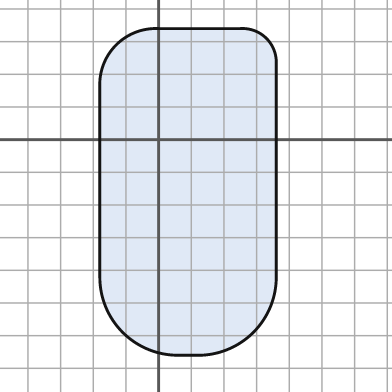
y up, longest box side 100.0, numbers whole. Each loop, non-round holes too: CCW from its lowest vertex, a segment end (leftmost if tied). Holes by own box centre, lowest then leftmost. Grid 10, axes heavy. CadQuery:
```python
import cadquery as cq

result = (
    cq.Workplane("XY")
    .moveTo(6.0, -66.0)
    .lineTo(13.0, -66.0)
    .threePointArc((29.0, -59.0), (36.0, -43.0))
    .lineTo(36.0, 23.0)
    .threePointArc((33.0, 31.0), (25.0, 34.0))
    .lineTo(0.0, 34.0)
    .threePointArc((-13.0, 29.0), (-18.0, 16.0))
    .lineTo(-18.0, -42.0)
    .threePointArc((-11.0, -59.0), (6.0, -66.0))
    .close()
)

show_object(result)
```